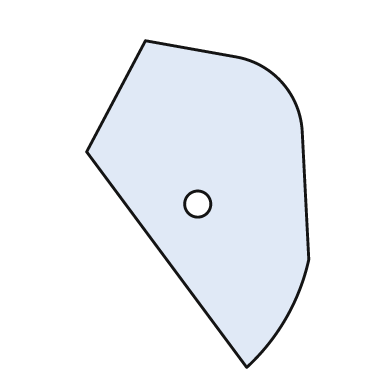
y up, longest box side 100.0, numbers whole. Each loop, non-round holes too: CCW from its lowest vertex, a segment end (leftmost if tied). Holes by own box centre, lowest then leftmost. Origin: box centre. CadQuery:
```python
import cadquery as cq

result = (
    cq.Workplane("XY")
    .moveTo(15.0, -50.0)
    .threePointArc((27.0, -35.0), (34.0, -17.0))
    .lineTo(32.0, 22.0)
    .threePointArc((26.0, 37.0), (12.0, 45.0))
    .lineTo(-16.0, 50.0)
    .lineTo(-34.0, 16.0)
    .close()
    .moveTo(0.0, 0.0)
    .circle(4.0)
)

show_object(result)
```